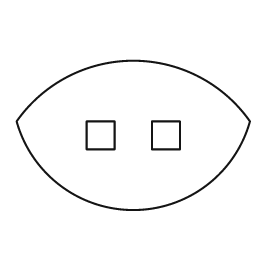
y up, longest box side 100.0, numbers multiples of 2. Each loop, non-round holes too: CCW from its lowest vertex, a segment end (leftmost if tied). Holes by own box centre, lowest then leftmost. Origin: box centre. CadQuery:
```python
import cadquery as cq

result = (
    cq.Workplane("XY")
    .moveTo(-50.0, 6.0)
    .threePointArc((0.0, -32.0), (50.0, 6.0))
    .threePointArc((0.0, 32.0), (-50.0, 6.0))
    .close()
    .moveTo(-20.0, -6.0)
    .lineTo(-8.0, -6.0)
    .lineTo(-8.0, 6.0)
    .lineTo(-20.0, 6.0)
    .close()
    .moveTo(8.0, -6.0)
    .lineTo(20.0, -6.0)
    .lineTo(20.0, 6.0)
    .lineTo(8.0, 6.0)
    .close()
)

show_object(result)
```